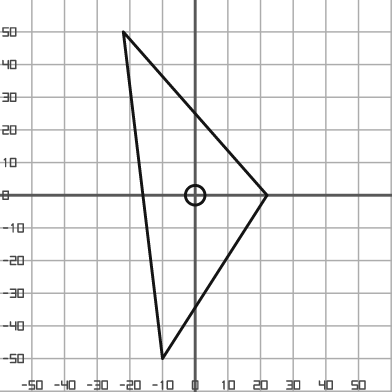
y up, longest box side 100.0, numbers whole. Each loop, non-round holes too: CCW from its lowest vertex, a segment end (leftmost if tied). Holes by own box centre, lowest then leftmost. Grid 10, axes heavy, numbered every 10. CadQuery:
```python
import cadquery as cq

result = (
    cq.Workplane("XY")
    .moveTo(-10.0, -50.0)
    .lineTo(22.0, 0.0)
    .lineTo(-22.0, 50.0)
    .close()
    .moveTo(0.0, 0.0)
    .circle(3.0)
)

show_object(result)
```